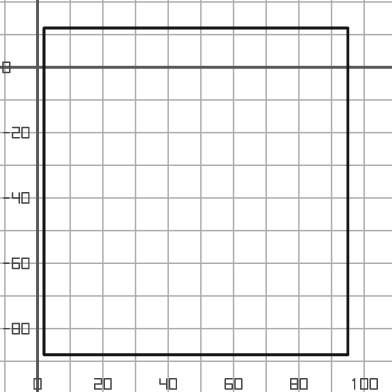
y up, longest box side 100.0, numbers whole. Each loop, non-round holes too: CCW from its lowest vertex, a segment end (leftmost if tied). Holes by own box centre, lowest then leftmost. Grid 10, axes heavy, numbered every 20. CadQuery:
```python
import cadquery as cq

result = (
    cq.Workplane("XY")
    .moveTo(2.0, -88.0)
    .lineTo(95.0, -88.0)
    .lineTo(95.0, 12.0)
    .lineTo(2.0, 12.0)
    .close()
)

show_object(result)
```